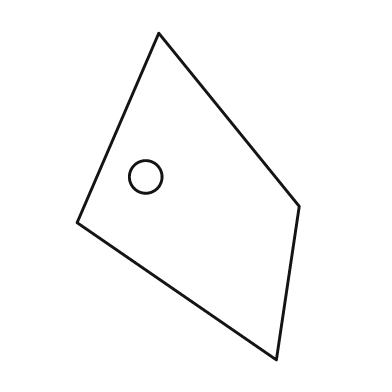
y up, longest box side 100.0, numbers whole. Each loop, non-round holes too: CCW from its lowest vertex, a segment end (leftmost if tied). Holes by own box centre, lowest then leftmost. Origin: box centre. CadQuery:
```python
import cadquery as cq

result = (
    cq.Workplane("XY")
    .moveTo(27.0, -50.0)
    .lineTo(34.0, -3.0)
    .lineTo(-9.0, 50.0)
    .lineTo(-34.0, -8.0)
    .close()
    .moveTo(-13.0, 6.0)
    .circle(5.0)
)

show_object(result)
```